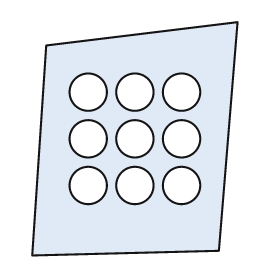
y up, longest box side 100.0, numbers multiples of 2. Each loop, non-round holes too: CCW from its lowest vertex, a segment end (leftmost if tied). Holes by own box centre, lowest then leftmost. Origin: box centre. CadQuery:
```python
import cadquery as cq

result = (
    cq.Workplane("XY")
    .moveTo(-44.0, -50.0)
    .lineTo(36.0, -48.0)
    .lineTo(44.0, 50.0)
    .lineTo(-38.0, 40.0)
    .close()
    .moveTo(-20.0, -20.0)
    .circle(8.0)
    .moveTo(0.0, -20.0)
    .circle(8.0)
    .moveTo(20.0, -20.0)
    .circle(8.0)
    .moveTo(-20.0, 0.0)
    .circle(8.0)
    .moveTo(0.0, 0.0)
    .circle(8.0)
    .moveTo(20.0, 0.0)
    .circle(8.0)
    .moveTo(-20.0, 20.0)
    .circle(8.0)
    .moveTo(0.0, 20.0)
    .circle(8.0)
    .moveTo(20.0, 20.0)
    .circle(8.0)
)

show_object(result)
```